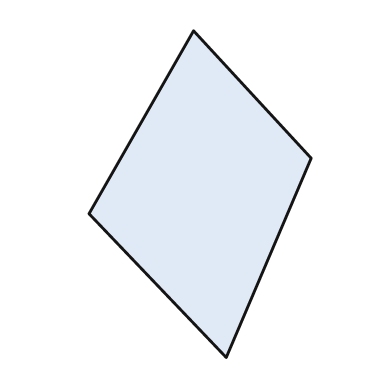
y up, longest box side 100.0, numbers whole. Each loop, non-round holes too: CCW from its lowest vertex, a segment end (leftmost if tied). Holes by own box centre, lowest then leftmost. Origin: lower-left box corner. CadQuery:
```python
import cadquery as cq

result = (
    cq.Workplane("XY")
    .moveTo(42.0, 0.0)
    .lineTo(68.0, 61.0)
    .lineTo(32.0, 100.0)
    .lineTo(0.0, 44.0)
    .close()
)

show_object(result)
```